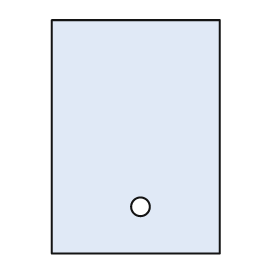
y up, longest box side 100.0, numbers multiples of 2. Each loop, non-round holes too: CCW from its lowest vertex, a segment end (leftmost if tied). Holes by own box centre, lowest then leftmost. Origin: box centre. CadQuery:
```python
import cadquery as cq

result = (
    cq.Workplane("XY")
    .moveTo(-36.0, -50.0)
    .lineTo(36.0, -50.0)
    .lineTo(36.0, 50.0)
    .lineTo(-36.0, 50.0)
    .close()
    .moveTo(2.0, -30.0)
    .circle(4.0)
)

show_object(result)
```